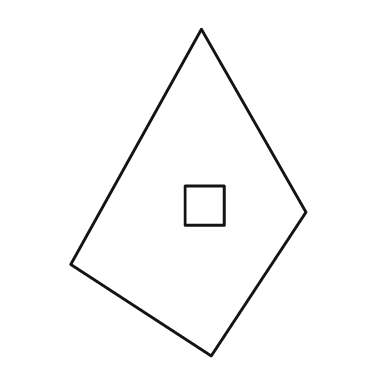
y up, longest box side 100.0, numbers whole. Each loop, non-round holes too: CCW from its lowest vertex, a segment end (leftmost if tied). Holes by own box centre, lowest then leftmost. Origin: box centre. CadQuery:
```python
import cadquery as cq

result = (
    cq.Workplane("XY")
    .moveTo(7.0, -50.0)
    .lineTo(36.0, -6.0)
    .lineTo(4.0, 50.0)
    .lineTo(-36.0, -22.0)
    .close()
    .moveTo(-1.0, -10.0)
    .lineTo(11.0, -10.0)
    .lineTo(11.0, 2.0)
    .lineTo(-1.0, 2.0)
    .close()
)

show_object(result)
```